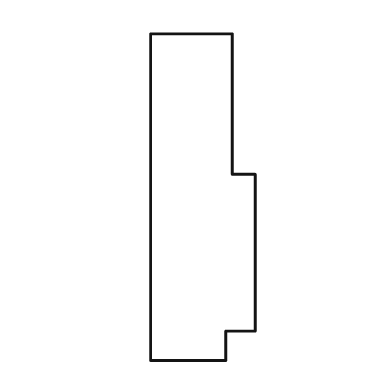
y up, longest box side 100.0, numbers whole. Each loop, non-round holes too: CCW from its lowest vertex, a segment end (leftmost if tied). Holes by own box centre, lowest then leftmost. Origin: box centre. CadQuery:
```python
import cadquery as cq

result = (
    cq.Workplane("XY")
    .moveTo(-16.0, -50.0)
    .lineTo(7.0, -50.0)
    .lineTo(7.0, -41.0)
    .lineTo(16.0, -41.0)
    .lineTo(16.0, 7.0)
    .lineTo(9.0, 7.0)
    .lineTo(9.0, 50.0)
    .lineTo(-16.0, 50.0)
    .close()
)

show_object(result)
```